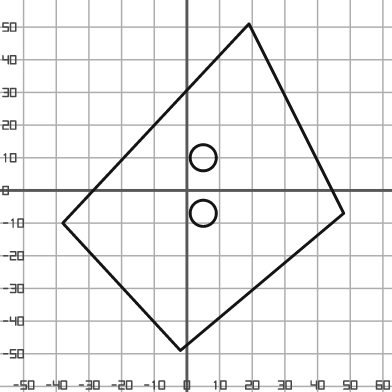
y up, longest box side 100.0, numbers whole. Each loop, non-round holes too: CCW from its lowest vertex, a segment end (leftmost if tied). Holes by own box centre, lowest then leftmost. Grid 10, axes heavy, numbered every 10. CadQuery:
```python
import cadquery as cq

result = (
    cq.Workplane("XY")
    .moveTo(-2.0, -49.0)
    .lineTo(48.0, -7.0)
    .lineTo(19.0, 51.0)
    .lineTo(-38.0, -10.0)
    .close()
    .moveTo(5.0, -7.0)
    .circle(4.0)
    .moveTo(5.0, 10.0)
    .circle(4.0)
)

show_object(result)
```